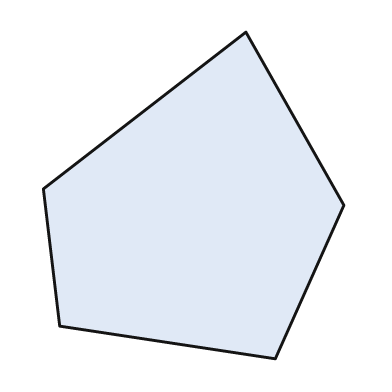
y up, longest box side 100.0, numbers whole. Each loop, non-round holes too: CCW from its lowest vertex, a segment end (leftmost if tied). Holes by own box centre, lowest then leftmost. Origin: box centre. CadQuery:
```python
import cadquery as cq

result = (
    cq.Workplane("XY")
    .moveTo(25.0, -50.0)
    .lineTo(46.0, -3.0)
    .lineTo(16.0, 50.0)
    .lineTo(-46.0, 2.0)
    .lineTo(-41.0, -40.0)
    .close()
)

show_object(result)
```